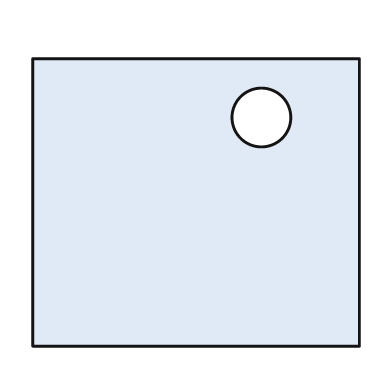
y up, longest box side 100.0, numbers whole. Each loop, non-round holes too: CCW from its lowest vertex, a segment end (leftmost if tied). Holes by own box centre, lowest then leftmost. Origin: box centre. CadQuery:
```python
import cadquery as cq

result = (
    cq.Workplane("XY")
    .moveTo(-50.0, -44.0)
    .lineTo(50.0, -44.0)
    .lineTo(50.0, 44.0)
    .lineTo(-50.0, 44.0)
    .close()
    .moveTo(20.0, 26.0)
    .circle(9.0)
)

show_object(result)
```